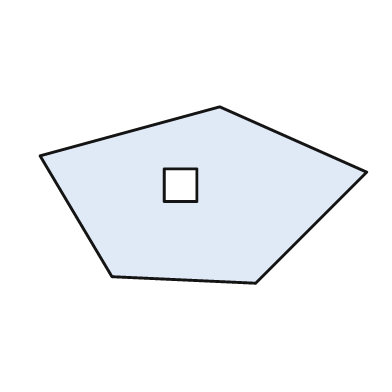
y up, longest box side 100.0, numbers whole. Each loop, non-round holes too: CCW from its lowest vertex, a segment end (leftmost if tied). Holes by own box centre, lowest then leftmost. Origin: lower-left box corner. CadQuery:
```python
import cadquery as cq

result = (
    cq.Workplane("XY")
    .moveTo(66.0, 0.0)
    .lineTo(100.0, 34.0)
    .lineTo(55.0, 54.0)
    .lineTo(0.0, 39.0)
    .lineTo(22.0, 2.0)
    .close()
    .moveTo(38.0, 25.0)
    .lineTo(48.0, 25.0)
    .lineTo(48.0, 35.0)
    .lineTo(38.0, 35.0)
    .close()
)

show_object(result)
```